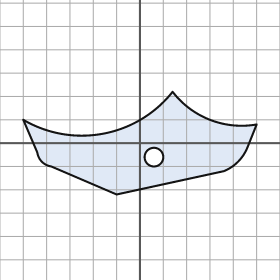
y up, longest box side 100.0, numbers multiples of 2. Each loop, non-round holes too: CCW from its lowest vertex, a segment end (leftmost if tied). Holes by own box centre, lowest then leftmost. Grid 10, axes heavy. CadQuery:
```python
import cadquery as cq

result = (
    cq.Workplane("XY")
    .moveTo(-10.0, -22.0)
    .lineTo(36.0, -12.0)
    .threePointArc((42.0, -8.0), (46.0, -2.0))
    .lineTo(50.0, 8.0)
    .threePointArc((30.0, 10.0), (14.0, 22.0))
    .threePointArc((-16.0, 4.0), (-50.0, 10.0))
    .lineTo(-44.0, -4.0)
    .threePointArc((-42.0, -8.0), (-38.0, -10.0))
    .close()
    .moveTo(6.0, -6.0)
    .circle(4.0)
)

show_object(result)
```